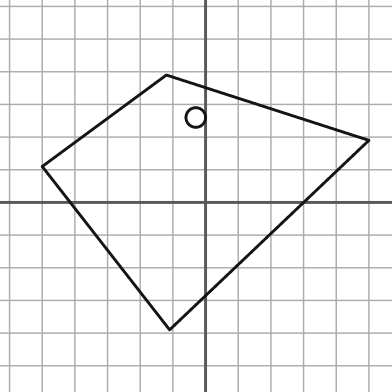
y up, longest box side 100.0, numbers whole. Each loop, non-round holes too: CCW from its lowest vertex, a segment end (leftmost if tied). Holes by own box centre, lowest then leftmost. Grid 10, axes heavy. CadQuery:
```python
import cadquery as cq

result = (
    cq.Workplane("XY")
    .moveTo(-11.0, -39.0)
    .lineTo(50.0, 19.0)
    .lineTo(-12.0, 39.0)
    .lineTo(-50.0, 11.0)
    .close()
    .moveTo(-3.0, 26.0)
    .circle(3.0)
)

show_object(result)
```